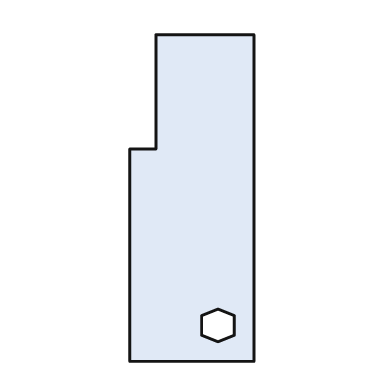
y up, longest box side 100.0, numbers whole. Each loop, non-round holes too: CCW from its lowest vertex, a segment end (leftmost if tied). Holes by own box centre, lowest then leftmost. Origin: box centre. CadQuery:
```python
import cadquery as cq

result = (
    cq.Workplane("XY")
    .moveTo(-19.0, -50.0)
    .lineTo(19.0, -50.0)
    .lineTo(19.0, 50.0)
    .lineTo(-11.0, 50.0)
    .lineTo(-11.0, 15.0)
    .lineTo(-19.0, 15.0)
    .close()
    .moveTo(8.0, -44.0)
    .lineTo(13.0, -42.0)
    .lineTo(13.0, -36.0)
    .lineTo(8.0, -34.0)
    .lineTo(3.0, -36.0)
    .lineTo(3.0, -42.0)
    .close()
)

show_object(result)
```